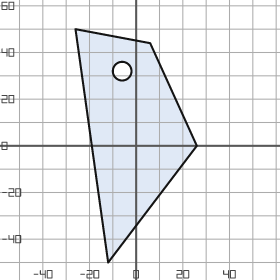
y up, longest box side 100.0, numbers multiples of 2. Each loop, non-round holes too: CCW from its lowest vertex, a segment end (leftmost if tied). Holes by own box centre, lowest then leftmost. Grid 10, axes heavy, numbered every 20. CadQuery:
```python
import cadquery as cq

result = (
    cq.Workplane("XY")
    .moveTo(-12.0, -50.0)
    .lineTo(26.0, 0.0)
    .lineTo(6.0, 44.0)
    .lineTo(-26.0, 50.0)
    .close()
    .moveTo(-6.0, 32.0)
    .circle(4.0)
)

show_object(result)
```